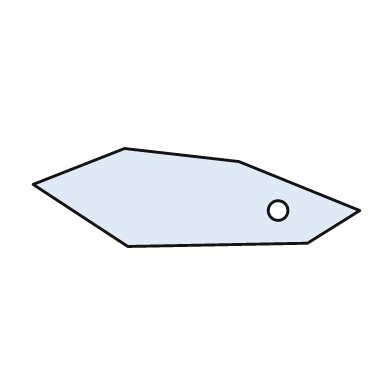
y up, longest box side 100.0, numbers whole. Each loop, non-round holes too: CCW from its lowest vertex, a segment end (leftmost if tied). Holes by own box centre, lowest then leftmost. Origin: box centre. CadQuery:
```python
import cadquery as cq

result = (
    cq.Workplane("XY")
    .moveTo(-21.0, -15.0)
    .lineTo(34.0, -14.0)
    .lineTo(50.0, -4.0)
    .lineTo(13.0, 11.0)
    .lineTo(-22.0, 15.0)
    .lineTo(-50.0, 4.0)
    .close()
    .moveTo(25.0, -4.0)
    .circle(3.0)
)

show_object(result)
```